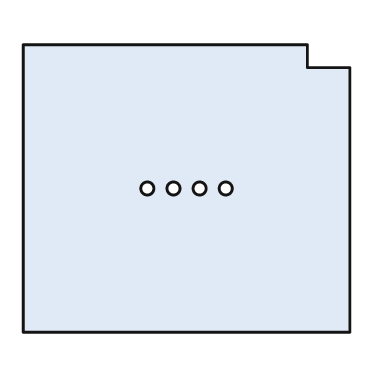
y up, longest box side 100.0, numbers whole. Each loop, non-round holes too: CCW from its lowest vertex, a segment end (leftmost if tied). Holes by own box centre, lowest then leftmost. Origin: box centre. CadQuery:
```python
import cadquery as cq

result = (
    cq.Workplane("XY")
    .moveTo(-50.0, -44.0)
    .lineTo(50.0, -44.0)
    .lineTo(50.0, 37.0)
    .lineTo(37.0, 37.0)
    .lineTo(37.0, 44.0)
    .lineTo(-50.0, 44.0)
    .close()
    .moveTo(-12.0, 0.0)
    .circle(2.0)
    .moveTo(-4.0, 0.0)
    .circle(2.0)
    .moveTo(4.0, 0.0)
    .circle(2.0)
    .moveTo(12.0, 0.0)
    .circle(2.0)
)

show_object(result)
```